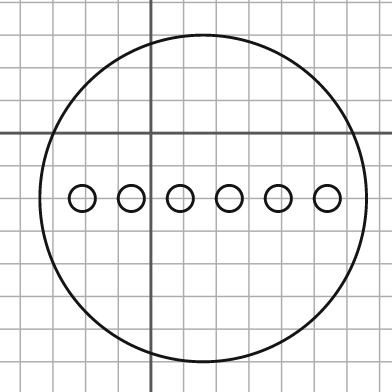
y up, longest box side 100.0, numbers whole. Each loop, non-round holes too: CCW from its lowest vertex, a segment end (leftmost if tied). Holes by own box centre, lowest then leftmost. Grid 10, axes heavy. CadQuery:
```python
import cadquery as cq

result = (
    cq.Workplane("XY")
    .moveTo(16.0, -20.0)
    .circle(50.0)
    .moveTo(-21.0, -20.0)
    .circle(4.0)
    .moveTo(-6.0, -20.0)
    .circle(4.0)
    .moveTo(9.0, -20.0)
    .circle(4.0)
    .moveTo(24.0, -20.0)
    .circle(4.0)
    .moveTo(39.0, -20.0)
    .circle(4.0)
    .moveTo(54.0, -20.0)
    .circle(4.0)
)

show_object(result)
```